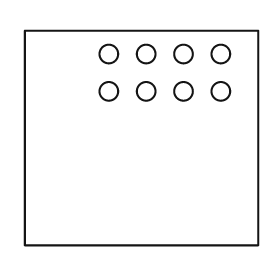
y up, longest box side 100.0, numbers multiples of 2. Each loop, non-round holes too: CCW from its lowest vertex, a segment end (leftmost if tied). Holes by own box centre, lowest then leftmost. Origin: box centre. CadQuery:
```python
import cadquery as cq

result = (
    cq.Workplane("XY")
    .moveTo(-50.0, -46.0)
    .lineTo(50.0, -46.0)
    .lineTo(50.0, 46.0)
    .lineTo(-50.0, 46.0)
    .close()
    .moveTo(-14.0, 20.0)
    .circle(4.0)
    .moveTo(2.0, 20.0)
    .circle(4.0)
    .moveTo(18.0, 20.0)
    .circle(4.0)
    .moveTo(34.0, 20.0)
    .circle(4.0)
    .moveTo(-14.0, 36.0)
    .circle(4.0)
    .moveTo(2.0, 36.0)
    .circle(4.0)
    .moveTo(18.0, 36.0)
    .circle(4.0)
    .moveTo(34.0, 36.0)
    .circle(4.0)
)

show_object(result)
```